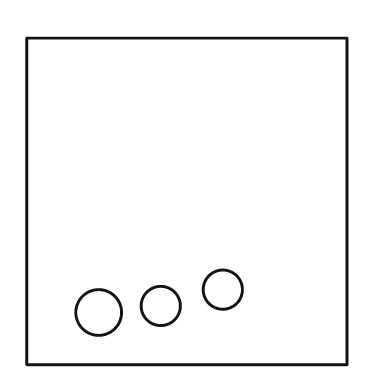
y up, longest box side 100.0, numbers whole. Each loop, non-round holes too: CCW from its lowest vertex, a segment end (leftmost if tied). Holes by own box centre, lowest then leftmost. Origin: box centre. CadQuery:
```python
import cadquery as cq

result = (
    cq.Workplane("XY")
    .moveTo(-49.0, -50.0)
    .lineTo(49.0, -50.0)
    .lineTo(49.0, 50.0)
    .lineTo(-49.0, 50.0)
    .close()
    .moveTo(-27.0, -34.0)
    .circle(7.0)
    .moveTo(-8.0, -32.0)
    .circle(6.0)
    .moveTo(11.0, -27.0)
    .circle(6.0)
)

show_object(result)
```